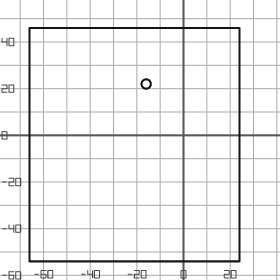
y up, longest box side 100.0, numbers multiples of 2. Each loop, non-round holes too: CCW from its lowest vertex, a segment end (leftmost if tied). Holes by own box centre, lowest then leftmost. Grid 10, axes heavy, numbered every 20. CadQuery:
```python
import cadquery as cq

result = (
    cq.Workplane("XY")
    .moveTo(-66.0, -54.0)
    .lineTo(24.0, -54.0)
    .lineTo(24.0, 46.0)
    .lineTo(-66.0, 46.0)
    .close()
    .moveTo(-16.0, 22.0)
    .circle(2.0)
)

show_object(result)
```